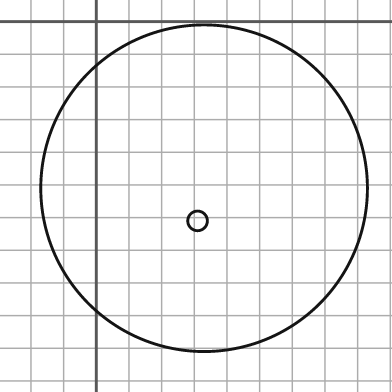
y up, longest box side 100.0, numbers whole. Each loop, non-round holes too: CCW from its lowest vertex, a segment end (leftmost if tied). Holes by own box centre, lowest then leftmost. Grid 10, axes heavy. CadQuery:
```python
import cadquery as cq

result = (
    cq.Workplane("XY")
    .moveTo(33.0, -51.0)
    .circle(50.0)
    .moveTo(31.0, -61.0)
    .circle(3.0)
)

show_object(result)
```